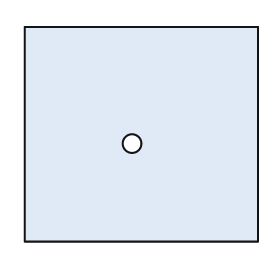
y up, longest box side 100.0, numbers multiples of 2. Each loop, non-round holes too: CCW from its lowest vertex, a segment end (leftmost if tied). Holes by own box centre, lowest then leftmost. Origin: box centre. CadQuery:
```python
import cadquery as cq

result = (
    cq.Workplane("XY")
    .moveTo(-50.0, -46.0)
    .lineTo(50.0, -46.0)
    .lineTo(50.0, 46.0)
    .lineTo(-50.0, 46.0)
    .close()
    .moveTo(-4.0, -4.0)
    .circle(4.0)
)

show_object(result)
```